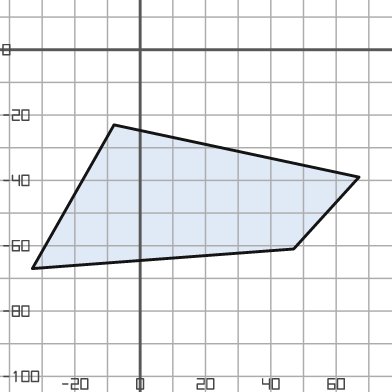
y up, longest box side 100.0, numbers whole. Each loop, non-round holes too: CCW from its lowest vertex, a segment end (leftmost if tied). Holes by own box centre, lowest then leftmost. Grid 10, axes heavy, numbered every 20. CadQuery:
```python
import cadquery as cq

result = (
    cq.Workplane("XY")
    .moveTo(-33.0, -67.0)
    .lineTo(47.0, -61.0)
    .lineTo(67.0, -39.0)
    .lineTo(-8.0, -23.0)
    .close()
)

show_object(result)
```